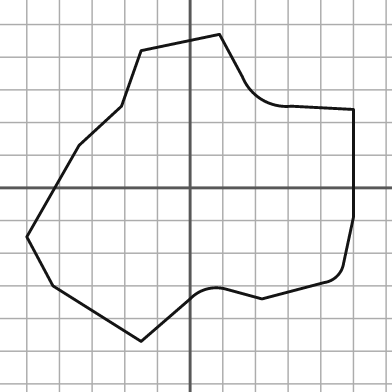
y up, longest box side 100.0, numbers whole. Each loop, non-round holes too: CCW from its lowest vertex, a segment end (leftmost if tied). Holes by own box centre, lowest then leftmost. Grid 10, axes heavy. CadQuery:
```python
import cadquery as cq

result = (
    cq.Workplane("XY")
    .moveTo(-15.0, -47.0)
    .lineTo(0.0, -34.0)
    .threePointArc((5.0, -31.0), (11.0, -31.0))
    .lineTo(22.0, -34.0)
    .lineTo(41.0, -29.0)
    .threePointArc((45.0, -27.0), (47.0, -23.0))
    .lineTo(50.0, -9.0)
    .lineTo(50.0, 24.0)
    .lineTo(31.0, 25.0)
    .threePointArc((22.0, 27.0), (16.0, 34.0))
    .lineTo(9.0, 47.0)
    .lineTo(-15.0, 42.0)
    .lineTo(-21.0, 25.0)
    .lineTo(-34.0, 13.0)
    .lineTo(-50.0, -15.0)
    .lineTo(-42.0, -30.0)
    .close()
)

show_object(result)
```